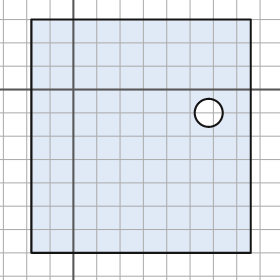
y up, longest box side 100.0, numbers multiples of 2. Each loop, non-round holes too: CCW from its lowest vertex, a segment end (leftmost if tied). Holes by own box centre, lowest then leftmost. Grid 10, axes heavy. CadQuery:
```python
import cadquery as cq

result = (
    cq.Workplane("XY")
    .moveTo(-18.0, -70.0)
    .lineTo(76.0, -70.0)
    .lineTo(76.0, 30.0)
    .lineTo(-18.0, 30.0)
    .close()
    .moveTo(58.0, -10.0)
    .circle(6.0)
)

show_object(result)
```